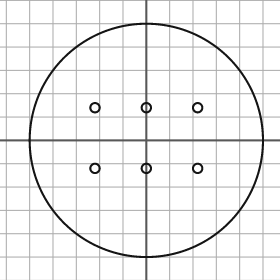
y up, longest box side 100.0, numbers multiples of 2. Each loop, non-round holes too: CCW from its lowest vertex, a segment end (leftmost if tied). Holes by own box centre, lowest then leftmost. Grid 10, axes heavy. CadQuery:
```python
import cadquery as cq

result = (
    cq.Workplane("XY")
    .moveTo(0.0, 0.0)
    .circle(50.0)
    .moveTo(-22.0, -12.0)
    .circle(2.0)
    .moveTo(0.0, -12.0)
    .circle(2.0)
    .moveTo(22.0, -12.0)
    .circle(2.0)
    .moveTo(-22.0, 14.0)
    .circle(2.0)
    .moveTo(0.0, 14.0)
    .circle(2.0)
    .moveTo(22.0, 14.0)
    .circle(2.0)
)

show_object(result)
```